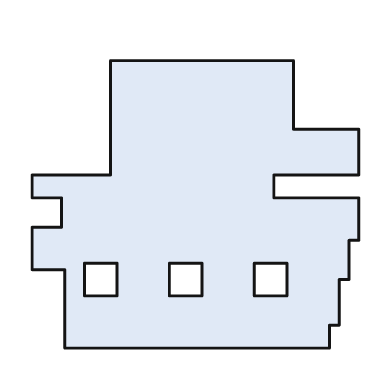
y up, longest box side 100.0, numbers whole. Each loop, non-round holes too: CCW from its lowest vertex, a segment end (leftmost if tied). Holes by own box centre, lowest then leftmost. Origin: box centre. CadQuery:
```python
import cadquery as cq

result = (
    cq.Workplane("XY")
    .moveTo(-40.0, -44.0)
    .lineTo(41.0, -44.0)
    .lineTo(41.0, -37.0)
    .lineTo(44.0, -37.0)
    .lineTo(44.0, -23.0)
    .lineTo(47.0, -23.0)
    .lineTo(47.0, -11.0)
    .lineTo(50.0, -11.0)
    .lineTo(50.0, 2.0)
    .lineTo(24.0, 2.0)
    .lineTo(24.0, 9.0)
    .lineTo(50.0, 9.0)
    .lineTo(50.0, 23.0)
    .lineTo(30.0, 23.0)
    .lineTo(30.0, 44.0)
    .lineTo(-26.0, 44.0)
    .lineTo(-26.0, 9.0)
    .lineTo(-50.0, 9.0)
    .lineTo(-50.0, 2.0)
    .lineTo(-41.0, 2.0)
    .lineTo(-41.0, -7.0)
    .lineTo(-50.0, -7.0)
    .lineTo(-50.0, -20.0)
    .lineTo(-40.0, -20.0)
    .close()
    .moveTo(-34.0, -28.0)
    .lineTo(-24.0, -28.0)
    .lineTo(-24.0, -18.0)
    .lineTo(-34.0, -18.0)
    .close()
    .moveTo(-8.0, -28.0)
    .lineTo(2.0, -28.0)
    .lineTo(2.0, -18.0)
    .lineTo(-8.0, -18.0)
    .close()
    .moveTo(18.0, -28.0)
    .lineTo(28.0, -28.0)
    .lineTo(28.0, -18.0)
    .lineTo(18.0, -18.0)
    .close()
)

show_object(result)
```